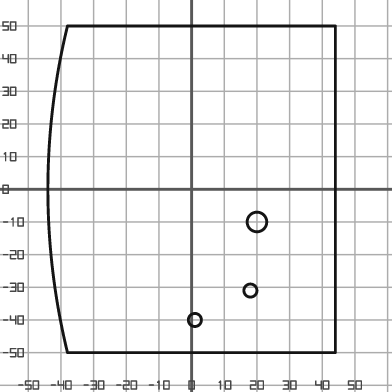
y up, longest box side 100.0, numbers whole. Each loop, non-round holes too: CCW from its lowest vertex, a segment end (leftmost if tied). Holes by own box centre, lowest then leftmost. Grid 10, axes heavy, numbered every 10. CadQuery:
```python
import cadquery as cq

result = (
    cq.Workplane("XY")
    .moveTo(-38.0, -50.0)
    .lineTo(44.0, -50.0)
    .lineTo(44.0, 50.0)
    .lineTo(-38.0, 50.0)
    .threePointArc((-44.0, 0.0), (-38.0, -50.0))
    .close()
    .moveTo(1.0, -40.0)
    .circle(2.0)
    .moveTo(18.0, -31.0)
    .circle(2.0)
    .moveTo(20.0, -10.0)
    .circle(3.0)
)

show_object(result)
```